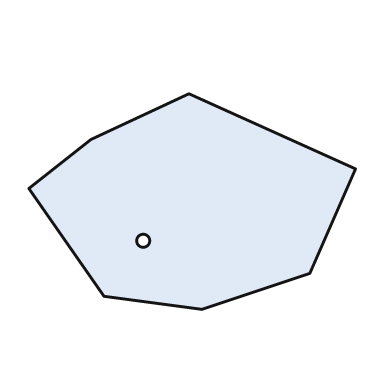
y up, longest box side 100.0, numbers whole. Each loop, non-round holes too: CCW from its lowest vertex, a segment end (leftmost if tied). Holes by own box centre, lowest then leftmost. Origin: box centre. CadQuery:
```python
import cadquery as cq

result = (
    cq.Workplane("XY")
    .moveTo(3.0, -33.0)
    .lineTo(36.0, -22.0)
    .lineTo(50.0, 10.0)
    .lineTo(-1.0, 33.0)
    .lineTo(-31.0, 19.0)
    .lineTo(-50.0, 4.0)
    .lineTo(-27.0, -29.0)
    .close()
    .moveTo(-15.0, -12.0)
    .circle(2.0)
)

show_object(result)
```